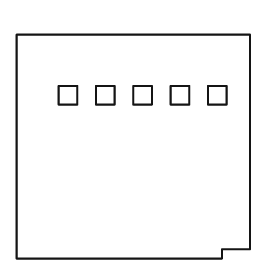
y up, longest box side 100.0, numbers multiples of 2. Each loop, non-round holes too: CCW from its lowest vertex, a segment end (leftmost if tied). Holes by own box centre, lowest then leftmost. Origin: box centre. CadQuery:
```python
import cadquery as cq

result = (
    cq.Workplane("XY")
    .moveTo(-50.0, -48.0)
    .lineTo(38.0, -48.0)
    .lineTo(38.0, -44.0)
    .lineTo(50.0, -44.0)
    .lineTo(50.0, 48.0)
    .lineTo(-50.0, 48.0)
    .close()
    .moveTo(-32.0, 18.0)
    .lineTo(-24.0, 18.0)
    .lineTo(-24.0, 26.0)
    .lineTo(-32.0, 26.0)
    .close()
    .moveTo(-16.0, 18.0)
    .lineTo(-8.0, 18.0)
    .lineTo(-8.0, 26.0)
    .lineTo(-16.0, 26.0)
    .close()
    .moveTo(0.0, 18.0)
    .lineTo(8.0, 18.0)
    .lineTo(8.0, 26.0)
    .lineTo(0.0, 26.0)
    .close()
    .moveTo(16.0, 18.0)
    .lineTo(24.0, 18.0)
    .lineTo(24.0, 26.0)
    .lineTo(16.0, 26.0)
    .close()
    .moveTo(32.0, 18.0)
    .lineTo(40.0, 18.0)
    .lineTo(40.0, 26.0)
    .lineTo(32.0, 26.0)
    .close()
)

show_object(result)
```